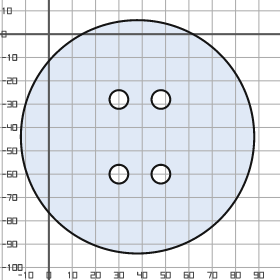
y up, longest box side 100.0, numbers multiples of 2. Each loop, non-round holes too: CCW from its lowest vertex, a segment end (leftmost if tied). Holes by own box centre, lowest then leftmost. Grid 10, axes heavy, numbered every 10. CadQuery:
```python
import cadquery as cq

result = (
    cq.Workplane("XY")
    .moveTo(38.0, -44.0)
    .circle(50.0)
    .moveTo(30.0, -60.0)
    .circle(4.0)
    .moveTo(48.0, -60.0)
    .circle(4.0)
    .moveTo(30.0, -28.0)
    .circle(4.0)
    .moveTo(48.0, -28.0)
    .circle(4.0)
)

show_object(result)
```